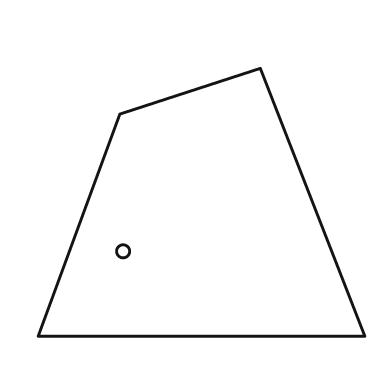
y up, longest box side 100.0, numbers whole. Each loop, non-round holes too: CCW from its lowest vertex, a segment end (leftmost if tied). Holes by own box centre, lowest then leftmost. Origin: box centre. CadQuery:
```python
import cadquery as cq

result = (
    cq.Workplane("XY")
    .moveTo(-50.0, -41.0)
    .lineTo(50.0, -41.0)
    .lineTo(18.0, 41.0)
    .lineTo(-25.0, 27.0)
    .close()
    .moveTo(-24.0, -15.0)
    .circle(2.0)
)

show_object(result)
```